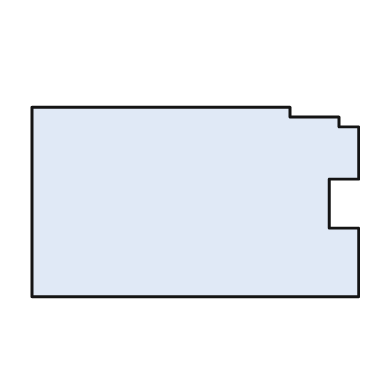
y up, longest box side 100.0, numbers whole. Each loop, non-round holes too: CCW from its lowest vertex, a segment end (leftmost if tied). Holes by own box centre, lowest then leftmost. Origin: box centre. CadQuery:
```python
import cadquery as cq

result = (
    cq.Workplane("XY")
    .moveTo(-50.0, -29.0)
    .lineTo(50.0, -29.0)
    .lineTo(50.0, -8.0)
    .lineTo(41.0, -8.0)
    .lineTo(41.0, 7.0)
    .lineTo(50.0, 7.0)
    .lineTo(50.0, 23.0)
    .lineTo(44.0, 23.0)
    .lineTo(44.0, 26.0)
    .lineTo(29.0, 26.0)
    .lineTo(29.0, 29.0)
    .lineTo(-50.0, 29.0)
    .close()
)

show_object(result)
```